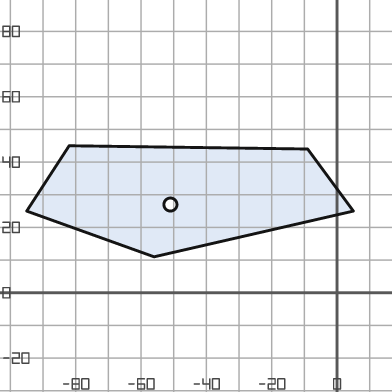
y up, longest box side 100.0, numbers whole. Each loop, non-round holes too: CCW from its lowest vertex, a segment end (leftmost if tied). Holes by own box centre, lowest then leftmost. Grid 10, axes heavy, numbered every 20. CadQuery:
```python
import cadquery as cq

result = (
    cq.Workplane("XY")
    .moveTo(-56.0, 11.0)
    .lineTo(5.0, 25.0)
    .lineTo(-9.0, 44.0)
    .lineTo(-82.0, 45.0)
    .lineTo(-95.0, 25.0)
    .close()
    .moveTo(-51.0, 27.0)
    .circle(2.0)
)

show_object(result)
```